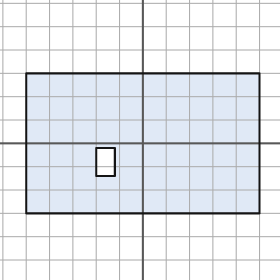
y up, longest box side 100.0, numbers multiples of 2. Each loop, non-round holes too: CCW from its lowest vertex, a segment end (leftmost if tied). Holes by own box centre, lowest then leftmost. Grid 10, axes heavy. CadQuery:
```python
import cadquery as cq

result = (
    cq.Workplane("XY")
    .moveTo(-50.0, -30.0)
    .lineTo(50.0, -30.0)
    .lineTo(50.0, 30.0)
    .lineTo(-50.0, 30.0)
    .close()
    .moveTo(-20.0, -14.0)
    .lineTo(-12.0, -14.0)
    .lineTo(-12.0, -2.0)
    .lineTo(-20.0, -2.0)
    .close()
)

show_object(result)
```